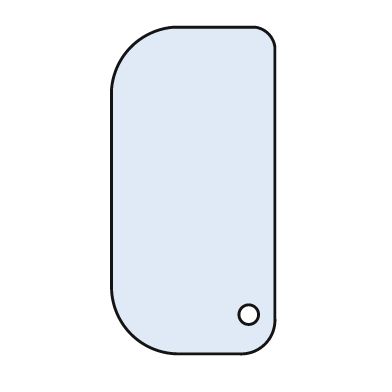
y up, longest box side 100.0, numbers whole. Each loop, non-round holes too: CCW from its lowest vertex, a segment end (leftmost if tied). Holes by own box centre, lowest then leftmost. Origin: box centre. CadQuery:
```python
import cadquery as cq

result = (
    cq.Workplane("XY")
    .moveTo(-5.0, -50.0)
    .lineTo(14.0, -50.0)
    .threePointArc((22.0, -47.0), (25.0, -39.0))
    .lineTo(25.0, 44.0)
    .threePointArc((23.0, 48.0), (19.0, 50.0))
    .lineTo(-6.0, 50.0)
    .threePointArc((-19.0, 44.0), (-25.0, 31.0))
    .lineTo(-25.0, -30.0)
    .threePointArc((-19.0, -44.0), (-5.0, -50.0))
    .close()
    .moveTo(17.0, -38.0)
    .circle(3.0)
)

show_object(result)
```